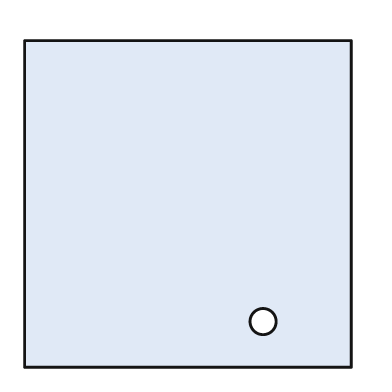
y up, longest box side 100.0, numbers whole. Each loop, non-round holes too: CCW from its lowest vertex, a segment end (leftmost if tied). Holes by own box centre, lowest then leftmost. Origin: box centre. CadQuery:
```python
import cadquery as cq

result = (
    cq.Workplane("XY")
    .moveTo(-50.0, -50.0)
    .lineTo(50.0, -50.0)
    .lineTo(50.0, 50.0)
    .lineTo(-50.0, 50.0)
    .close()
    .moveTo(23.0, -36.0)
    .circle(4.0)
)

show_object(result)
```